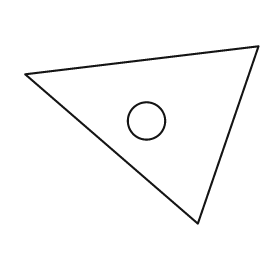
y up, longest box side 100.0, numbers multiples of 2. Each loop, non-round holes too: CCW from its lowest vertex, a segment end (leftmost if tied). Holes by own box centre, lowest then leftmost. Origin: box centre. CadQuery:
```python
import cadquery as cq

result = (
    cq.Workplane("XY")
    .moveTo(24.0, -38.0)
    .lineTo(50.0, 38.0)
    .lineTo(-50.0, 26.0)
    .close()
    .moveTo(2.0, 6.0)
    .circle(8.0)
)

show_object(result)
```